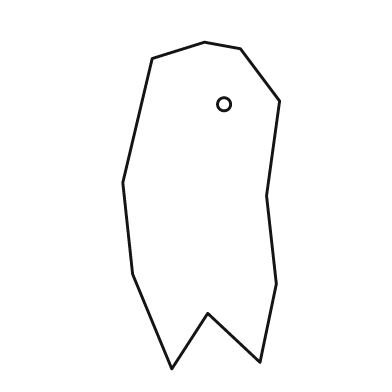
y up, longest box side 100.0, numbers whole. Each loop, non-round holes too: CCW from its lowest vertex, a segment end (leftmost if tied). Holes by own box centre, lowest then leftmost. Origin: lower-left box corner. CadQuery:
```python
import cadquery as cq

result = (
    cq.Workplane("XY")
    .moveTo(15.0, 0.0)
    .lineTo(26.0, 17.0)
    .lineTo(42.0, 2.0)
    .lineTo(47.0, 26.0)
    .lineTo(44.0, 53.0)
    .lineTo(48.0, 82.0)
    .lineTo(36.0, 98.0)
    .lineTo(25.0, 100.0)
    .lineTo(9.0, 95.0)
    .lineTo(0.0, 57.0)
    .lineTo(3.0, 29.0)
    .close()
    .moveTo(31.0, 81.0)
    .circle(2.0)
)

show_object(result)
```